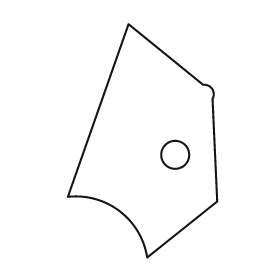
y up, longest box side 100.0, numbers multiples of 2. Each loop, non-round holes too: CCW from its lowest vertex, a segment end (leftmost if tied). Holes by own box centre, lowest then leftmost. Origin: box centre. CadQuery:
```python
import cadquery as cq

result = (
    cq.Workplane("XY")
    .moveTo(2.0, -50.0)
    .lineTo(32.0, -26.0)
    .lineTo(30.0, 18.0)
    .threePointArc((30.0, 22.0), (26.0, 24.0))
    .lineTo(-6.0, 50.0)
    .lineTo(-32.0, -24.0)
    .threePointArc((-10.0, -30.0), (2.0, -50.0))
    .close()
    .moveTo(14.0, -6.0)
    .circle(6.0)
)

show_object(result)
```